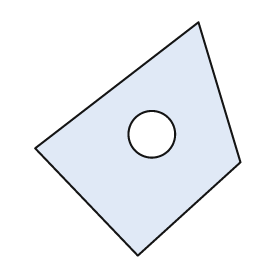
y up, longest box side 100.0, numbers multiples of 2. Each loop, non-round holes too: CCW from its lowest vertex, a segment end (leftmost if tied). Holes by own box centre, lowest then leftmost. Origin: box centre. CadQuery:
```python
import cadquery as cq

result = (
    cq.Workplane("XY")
    .moveTo(0.0, -50.0)
    .lineTo(44.0, -10.0)
    .lineTo(26.0, 50.0)
    .lineTo(-44.0, -4.0)
    .close()
    .moveTo(6.0, 2.0)
    .circle(10.0)
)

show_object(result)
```